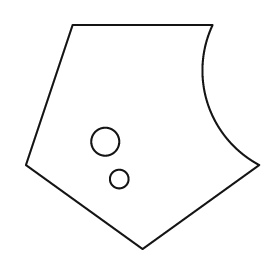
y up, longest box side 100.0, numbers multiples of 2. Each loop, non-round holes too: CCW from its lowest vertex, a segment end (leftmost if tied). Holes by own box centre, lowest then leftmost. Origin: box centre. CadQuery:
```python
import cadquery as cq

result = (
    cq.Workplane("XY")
    .moveTo(0.0, -48.0)
    .lineTo(50.0, -12.0)
    .threePointArc((28.0, 14.0), (30.0, 48.0))
    .lineTo(-30.0, 48.0)
    .lineTo(-50.0, -12.0)
    .close()
    .moveTo(-10.0, -18.0)
    .circle(4.0)
    .moveTo(-16.0, -2.0)
    .circle(6.0)
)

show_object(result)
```